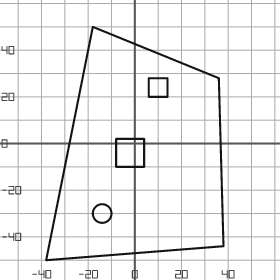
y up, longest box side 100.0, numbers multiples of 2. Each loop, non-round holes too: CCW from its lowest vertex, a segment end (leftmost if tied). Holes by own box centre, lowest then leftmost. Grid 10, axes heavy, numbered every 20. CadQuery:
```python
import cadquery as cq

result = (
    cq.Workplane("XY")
    .moveTo(-38.0, -50.0)
    .lineTo(38.0, -44.0)
    .lineTo(36.0, 28.0)
    .lineTo(-18.0, 50.0)
    .close()
    .moveTo(-14.0, -30.0)
    .circle(4.0)
    .moveTo(-8.0, -10.0)
    .lineTo(4.0, -10.0)
    .lineTo(4.0, 2.0)
    .lineTo(-8.0, 2.0)
    .close()
    .moveTo(6.0, 20.0)
    .lineTo(14.0, 20.0)
    .lineTo(14.0, 28.0)
    .lineTo(6.0, 28.0)
    .close()
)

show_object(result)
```